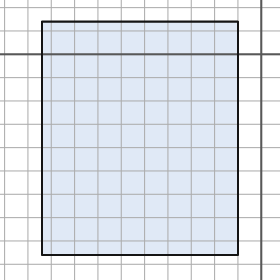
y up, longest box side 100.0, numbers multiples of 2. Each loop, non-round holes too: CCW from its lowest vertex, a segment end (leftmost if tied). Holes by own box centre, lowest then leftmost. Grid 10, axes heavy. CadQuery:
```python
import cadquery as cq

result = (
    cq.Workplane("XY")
    .moveTo(-94.0, -86.0)
    .lineTo(-10.0, -86.0)
    .lineTo(-10.0, 14.0)
    .lineTo(-94.0, 14.0)
    .close()
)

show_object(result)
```